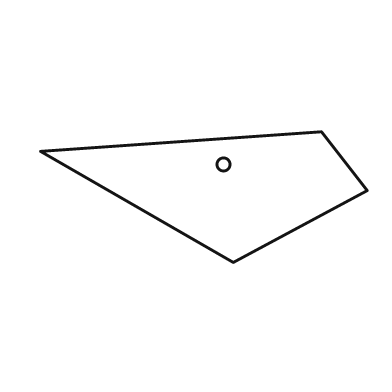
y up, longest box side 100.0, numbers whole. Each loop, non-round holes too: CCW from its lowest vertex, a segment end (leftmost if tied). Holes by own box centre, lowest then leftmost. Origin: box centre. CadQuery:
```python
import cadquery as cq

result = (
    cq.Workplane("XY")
    .moveTo(9.0, -20.0)
    .lineTo(50.0, 2.0)
    .lineTo(36.0, 20.0)
    .lineTo(-50.0, 14.0)
    .close()
    .moveTo(6.0, 10.0)
    .circle(2.0)
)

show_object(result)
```